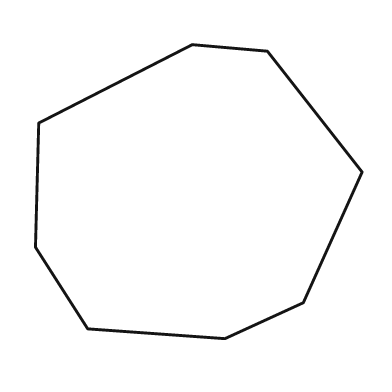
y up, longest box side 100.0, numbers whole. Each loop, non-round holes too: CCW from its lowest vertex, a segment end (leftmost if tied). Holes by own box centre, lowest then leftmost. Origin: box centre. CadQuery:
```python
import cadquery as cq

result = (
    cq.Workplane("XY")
    .moveTo(8.0, -45.0)
    .lineTo(32.0, -34.0)
    .lineTo(50.0, 6.0)
    .lineTo(21.0, 43.0)
    .lineTo(-2.0, 45.0)
    .lineTo(-49.0, 21.0)
    .lineTo(-50.0, -17.0)
    .lineTo(-34.0, -42.0)
    .close()
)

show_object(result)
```